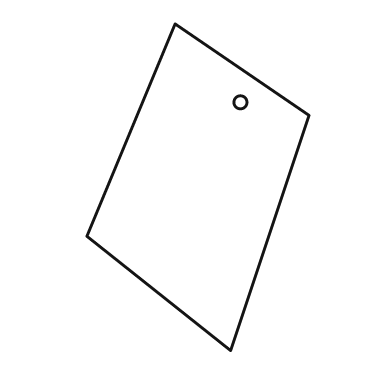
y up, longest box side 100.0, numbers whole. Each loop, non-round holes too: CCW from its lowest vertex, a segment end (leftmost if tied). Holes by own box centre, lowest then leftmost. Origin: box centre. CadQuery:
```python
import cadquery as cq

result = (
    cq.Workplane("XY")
    .moveTo(10.0, -50.0)
    .lineTo(34.0, 22.0)
    .lineTo(-7.0, 50.0)
    .lineTo(-34.0, -15.0)
    .close()
    .moveTo(13.0, 26.0)
    .circle(2.0)
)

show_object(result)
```